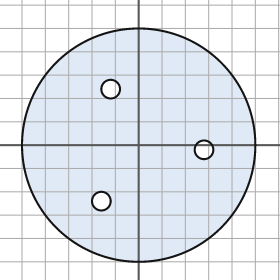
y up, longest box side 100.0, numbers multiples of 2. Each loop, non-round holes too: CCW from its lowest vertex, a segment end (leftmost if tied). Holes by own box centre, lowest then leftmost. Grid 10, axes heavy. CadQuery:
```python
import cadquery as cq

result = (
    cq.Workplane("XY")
    .moveTo(0.0, 0.0)
    .circle(50.0)
    .moveTo(-16.0, -24.0)
    .circle(4.0)
    .moveTo(28.0, -2.0)
    .circle(4.0)
    .moveTo(-12.0, 24.0)
    .circle(4.0)
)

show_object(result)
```